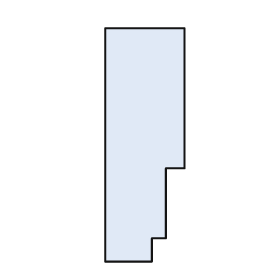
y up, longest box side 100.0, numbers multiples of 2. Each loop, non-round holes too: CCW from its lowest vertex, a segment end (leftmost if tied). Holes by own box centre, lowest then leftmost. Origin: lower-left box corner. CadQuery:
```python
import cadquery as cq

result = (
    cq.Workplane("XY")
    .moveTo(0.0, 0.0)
    .lineTo(20.0, 0.0)
    .lineTo(20.0, 10.0)
    .lineTo(26.0, 10.0)
    .lineTo(26.0, 40.0)
    .lineTo(34.0, 40.0)
    .lineTo(34.0, 100.0)
    .lineTo(0.0, 100.0)
    .close()
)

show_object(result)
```